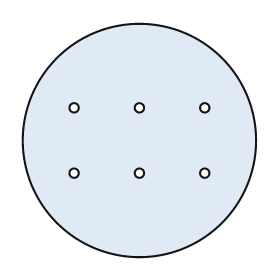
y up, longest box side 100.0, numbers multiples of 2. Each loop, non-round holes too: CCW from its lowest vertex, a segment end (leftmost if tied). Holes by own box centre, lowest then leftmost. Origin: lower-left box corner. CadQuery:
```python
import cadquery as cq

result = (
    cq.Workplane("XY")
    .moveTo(50.0, 50.0)
    .circle(50.0)
    .moveTo(22.0, 36.0)
    .circle(2.0)
    .moveTo(50.0, 36.0)
    .circle(2.0)
    .moveTo(78.0, 36.0)
    .circle(2.0)
    .moveTo(22.0, 64.0)
    .circle(2.0)
    .moveTo(50.0, 64.0)
    .circle(2.0)
    .moveTo(78.0, 64.0)
    .circle(2.0)
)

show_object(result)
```